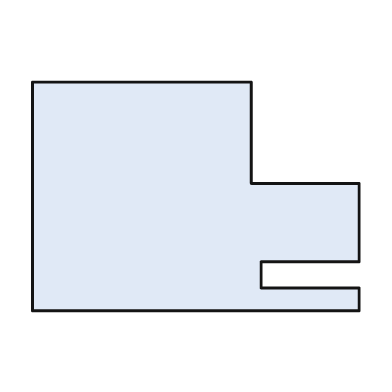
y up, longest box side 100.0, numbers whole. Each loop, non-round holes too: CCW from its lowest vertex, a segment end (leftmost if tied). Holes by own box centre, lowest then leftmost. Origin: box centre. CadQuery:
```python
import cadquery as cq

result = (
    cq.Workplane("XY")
    .moveTo(-50.0, -35.0)
    .lineTo(50.0, -35.0)
    .lineTo(50.0, -28.0)
    .lineTo(20.0, -28.0)
    .lineTo(20.0, -20.0)
    .lineTo(50.0, -20.0)
    .lineTo(50.0, 4.0)
    .lineTo(17.0, 4.0)
    .lineTo(17.0, 35.0)
    .lineTo(-50.0, 35.0)
    .close()
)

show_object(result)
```